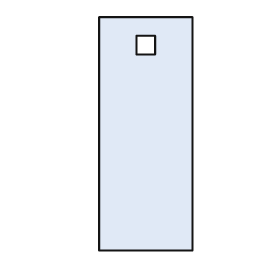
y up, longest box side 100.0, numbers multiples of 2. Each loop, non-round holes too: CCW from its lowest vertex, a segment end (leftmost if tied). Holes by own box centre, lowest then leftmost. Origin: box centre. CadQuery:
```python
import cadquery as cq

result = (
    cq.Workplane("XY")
    .moveTo(-20.0, -50.0)
    .lineTo(20.0, -50.0)
    .lineTo(20.0, 50.0)
    .lineTo(-20.0, 50.0)
    .close()
    .moveTo(-4.0, 34.0)
    .lineTo(4.0, 34.0)
    .lineTo(4.0, 42.0)
    .lineTo(-4.0, 42.0)
    .close()
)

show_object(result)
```